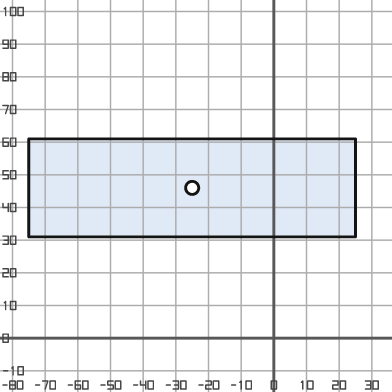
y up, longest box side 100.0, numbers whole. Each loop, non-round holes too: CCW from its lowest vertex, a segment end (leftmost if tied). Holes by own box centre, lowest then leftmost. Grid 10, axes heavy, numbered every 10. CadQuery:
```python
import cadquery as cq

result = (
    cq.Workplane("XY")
    .moveTo(-75.0, 31.0)
    .lineTo(25.0, 31.0)
    .lineTo(25.0, 61.0)
    .lineTo(-75.0, 61.0)
    .close()
    .moveTo(-25.0, 46.0)
    .circle(2.0)
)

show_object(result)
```